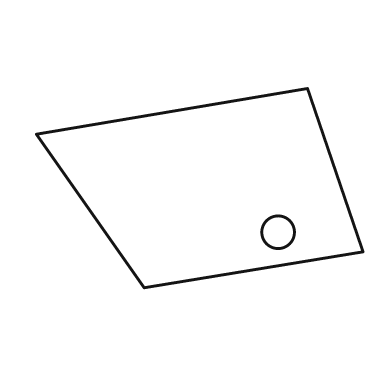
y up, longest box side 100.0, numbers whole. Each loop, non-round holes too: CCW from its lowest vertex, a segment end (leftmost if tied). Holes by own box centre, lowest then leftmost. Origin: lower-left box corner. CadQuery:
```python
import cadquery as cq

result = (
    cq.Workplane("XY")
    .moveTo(33.0, 0.0)
    .lineTo(100.0, 11.0)
    .lineTo(83.0, 61.0)
    .lineTo(0.0, 47.0)
    .close()
    .moveTo(74.0, 17.0)
    .circle(5.0)
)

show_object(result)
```